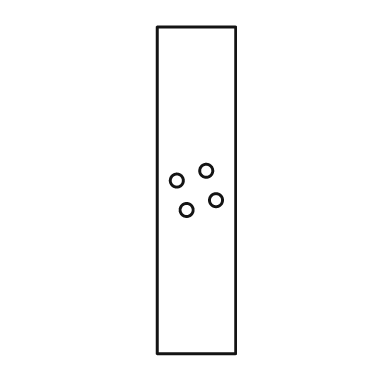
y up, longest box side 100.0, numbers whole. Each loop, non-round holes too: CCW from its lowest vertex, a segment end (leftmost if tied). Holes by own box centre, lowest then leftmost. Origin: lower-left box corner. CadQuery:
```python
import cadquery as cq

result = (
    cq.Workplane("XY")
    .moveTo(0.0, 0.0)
    .lineTo(24.0, 0.0)
    .lineTo(24.0, 100.0)
    .lineTo(0.0, 100.0)
    .close()
    .moveTo(9.0, 44.0)
    .circle(2.0)
    .moveTo(18.0, 47.0)
    .circle(2.0)
    .moveTo(6.0, 53.0)
    .circle(2.0)
    .moveTo(15.0, 56.0)
    .circle(2.0)
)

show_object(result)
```